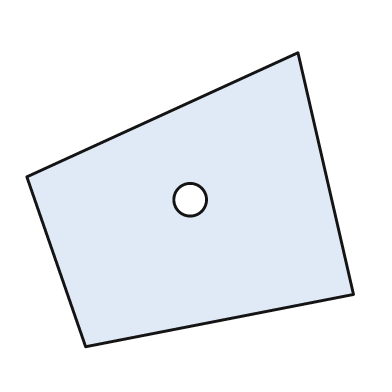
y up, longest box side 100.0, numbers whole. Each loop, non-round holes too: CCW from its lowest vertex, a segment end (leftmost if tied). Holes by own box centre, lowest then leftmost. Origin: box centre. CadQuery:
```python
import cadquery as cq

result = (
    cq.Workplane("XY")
    .moveTo(-32.0, -45.0)
    .lineTo(50.0, -29.0)
    .lineTo(33.0, 45.0)
    .lineTo(-50.0, 7.0)
    .close()
    .moveTo(0.0, 0.0)
    .circle(5.0)
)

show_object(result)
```